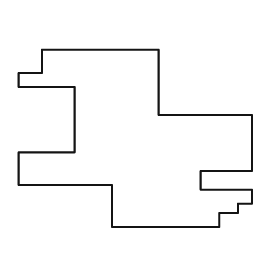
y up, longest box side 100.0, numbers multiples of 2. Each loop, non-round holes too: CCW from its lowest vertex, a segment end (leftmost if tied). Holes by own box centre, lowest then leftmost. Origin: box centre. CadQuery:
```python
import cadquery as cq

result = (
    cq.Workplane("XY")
    .moveTo(-10.0, -38.0)
    .lineTo(36.0, -38.0)
    .lineTo(36.0, -32.0)
    .lineTo(44.0, -32.0)
    .lineTo(44.0, -28.0)
    .lineTo(50.0, -28.0)
    .lineTo(50.0, -22.0)
    .lineTo(28.0, -22.0)
    .lineTo(28.0, -14.0)
    .lineTo(50.0, -14.0)
    .lineTo(50.0, 10.0)
    .lineTo(10.0, 10.0)
    .lineTo(10.0, 38.0)
    .lineTo(-40.0, 38.0)
    .lineTo(-40.0, 28.0)
    .lineTo(-50.0, 28.0)
    .lineTo(-50.0, 22.0)
    .lineTo(-26.0, 22.0)
    .lineTo(-26.0, -6.0)
    .lineTo(-50.0, -6.0)
    .lineTo(-50.0, -20.0)
    .lineTo(-10.0, -20.0)
    .close()
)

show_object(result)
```